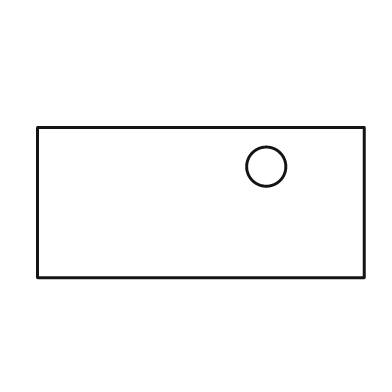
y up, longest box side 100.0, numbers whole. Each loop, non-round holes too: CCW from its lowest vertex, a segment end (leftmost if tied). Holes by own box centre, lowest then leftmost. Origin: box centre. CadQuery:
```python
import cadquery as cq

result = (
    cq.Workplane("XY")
    .moveTo(-50.0, -23.0)
    .lineTo(50.0, -23.0)
    .lineTo(50.0, 23.0)
    .lineTo(-50.0, 23.0)
    .close()
    .moveTo(20.0, 11.0)
    .circle(6.0)
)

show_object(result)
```